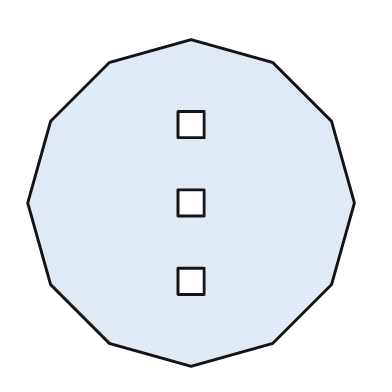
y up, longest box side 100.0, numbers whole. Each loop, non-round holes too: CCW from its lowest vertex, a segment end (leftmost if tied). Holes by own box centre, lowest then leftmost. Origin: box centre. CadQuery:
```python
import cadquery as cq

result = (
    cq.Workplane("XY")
    .moveTo(0.0, -50.0)
    .lineTo(25.0, -43.0)
    .lineTo(43.0, -25.0)
    .lineTo(50.0, 0.0)
    .lineTo(43.0, 25.0)
    .lineTo(25.0, 43.0)
    .lineTo(0.0, 50.0)
    .lineTo(-25.0, 43.0)
    .lineTo(-43.0, 25.0)
    .lineTo(-50.0, 0.0)
    .lineTo(-43.0, -25.0)
    .lineTo(-25.0, -43.0)
    .close()
    .moveTo(-4.0, -28.0)
    .lineTo(4.0, -28.0)
    .lineTo(4.0, -20.0)
    .lineTo(-4.0, -20.0)
    .close()
    .moveTo(-4.0, -4.0)
    .lineTo(4.0, -4.0)
    .lineTo(4.0, 4.0)
    .lineTo(-4.0, 4.0)
    .close()
    .moveTo(-4.0, 20.0)
    .lineTo(4.0, 20.0)
    .lineTo(4.0, 28.0)
    .lineTo(-4.0, 28.0)
    .close()
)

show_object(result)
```